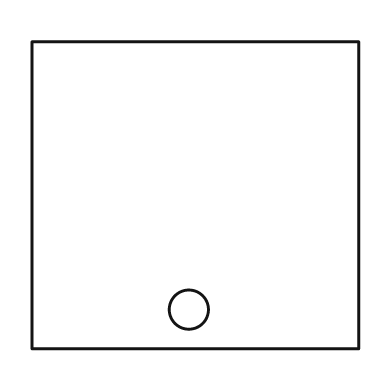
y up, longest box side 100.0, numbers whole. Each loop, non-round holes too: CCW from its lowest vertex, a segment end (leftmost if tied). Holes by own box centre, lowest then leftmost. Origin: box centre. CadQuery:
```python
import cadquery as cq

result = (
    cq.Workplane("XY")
    .moveTo(-50.0, -47.0)
    .lineTo(50.0, -47.0)
    .lineTo(50.0, 47.0)
    .lineTo(-50.0, 47.0)
    .close()
    .moveTo(-2.0, -35.0)
    .circle(6.0)
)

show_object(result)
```